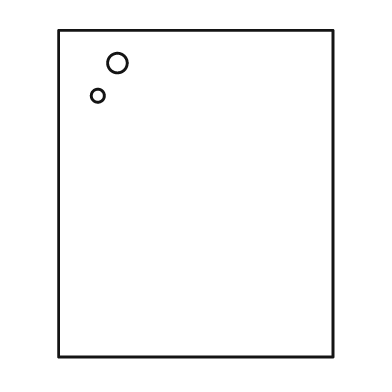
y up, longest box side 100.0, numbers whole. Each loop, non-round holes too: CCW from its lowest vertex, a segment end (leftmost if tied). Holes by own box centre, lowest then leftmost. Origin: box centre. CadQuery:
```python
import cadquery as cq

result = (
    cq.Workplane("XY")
    .moveTo(-42.0, -50.0)
    .lineTo(42.0, -50.0)
    .lineTo(42.0, 50.0)
    .lineTo(-42.0, 50.0)
    .close()
    .moveTo(-30.0, 30.0)
    .circle(2.0)
    .moveTo(-24.0, 40.0)
    .circle(3.0)
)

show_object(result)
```